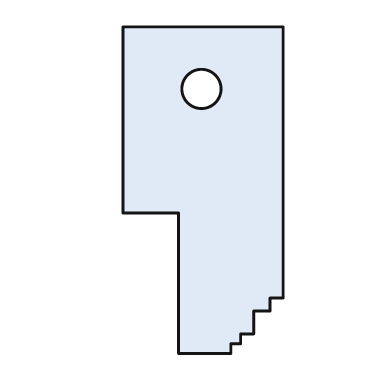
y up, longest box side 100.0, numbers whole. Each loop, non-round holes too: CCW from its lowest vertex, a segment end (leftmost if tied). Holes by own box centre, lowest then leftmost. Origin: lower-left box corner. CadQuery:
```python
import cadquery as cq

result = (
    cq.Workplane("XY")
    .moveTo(17.0, 0.0)
    .lineTo(33.0, 0.0)
    .lineTo(33.0, 3.0)
    .lineTo(36.0, 3.0)
    .lineTo(36.0, 6.0)
    .lineTo(40.0, 6.0)
    .lineTo(40.0, 13.0)
    .lineTo(45.0, 13.0)
    .lineTo(45.0, 17.0)
    .lineTo(49.0, 17.0)
    .lineTo(49.0, 100.0)
    .lineTo(0.0, 100.0)
    .lineTo(0.0, 43.0)
    .lineTo(17.0, 43.0)
    .close()
    .moveTo(24.0, 81.0)
    .circle(6.0)
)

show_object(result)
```